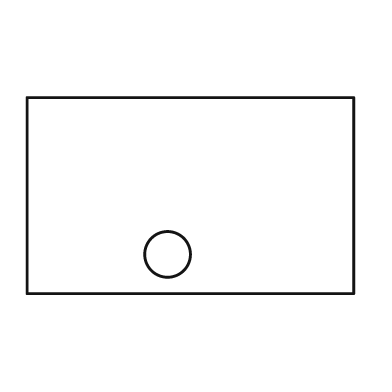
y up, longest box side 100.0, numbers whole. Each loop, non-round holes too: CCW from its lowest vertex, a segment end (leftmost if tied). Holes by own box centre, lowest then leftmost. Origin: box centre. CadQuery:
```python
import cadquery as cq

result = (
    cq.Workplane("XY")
    .moveTo(-50.0, -30.0)
    .lineTo(50.0, -30.0)
    .lineTo(50.0, 30.0)
    .lineTo(-50.0, 30.0)
    .close()
    .moveTo(-7.0, -18.0)
    .circle(7.0)
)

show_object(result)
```